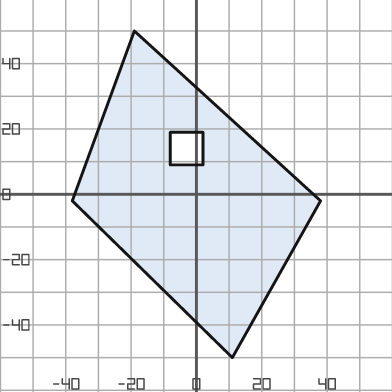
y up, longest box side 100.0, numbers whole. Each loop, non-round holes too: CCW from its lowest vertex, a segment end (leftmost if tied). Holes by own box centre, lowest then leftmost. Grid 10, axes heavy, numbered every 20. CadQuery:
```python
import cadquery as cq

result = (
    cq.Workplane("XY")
    .moveTo(11.0, -50.0)
    .lineTo(38.0, -2.0)
    .lineTo(-19.0, 50.0)
    .lineTo(-38.0, -2.0)
    .close()
    .moveTo(-8.0, 9.0)
    .lineTo(2.0, 9.0)
    .lineTo(2.0, 19.0)
    .lineTo(-8.0, 19.0)
    .close()
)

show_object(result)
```